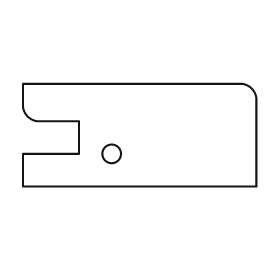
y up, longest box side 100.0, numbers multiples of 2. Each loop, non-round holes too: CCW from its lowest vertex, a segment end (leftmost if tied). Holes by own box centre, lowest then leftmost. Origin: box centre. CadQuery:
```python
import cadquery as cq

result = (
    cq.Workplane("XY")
    .moveTo(-50.0, -22.0)
    .lineTo(50.0, -22.0)
    .lineTo(50.0, 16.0)
    .threePointArc((48.0, 20.0), (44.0, 22.0))
    .lineTo(-50.0, 22.0)
    .lineTo(-50.0, 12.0)
    .threePointArc((-48.0, 8.0), (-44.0, 6.0))
    .lineTo(-26.0, 6.0)
    .lineTo(-26.0, -8.0)
    .lineTo(-50.0, -8.0)
    .close()
    .moveTo(-12.0, -8.0)
    .circle(4.0)
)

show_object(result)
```